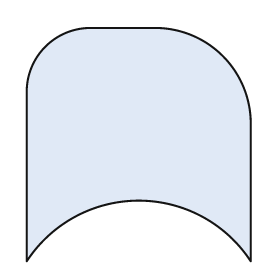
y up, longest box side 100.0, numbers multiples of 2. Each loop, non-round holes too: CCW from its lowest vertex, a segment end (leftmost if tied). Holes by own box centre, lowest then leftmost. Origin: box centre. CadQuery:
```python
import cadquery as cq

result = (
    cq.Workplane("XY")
    .moveTo(-48.0, -50.0)
    .threePointArc((0.0, -24.0), (48.0, -50.0))
    .lineTo(48.0, 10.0)
    .threePointArc((36.0, 38.0), (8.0, 50.0))
    .lineTo(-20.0, 50.0)
    .threePointArc((-40.0, 42.0), (-48.0, 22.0))
    .close()
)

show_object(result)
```